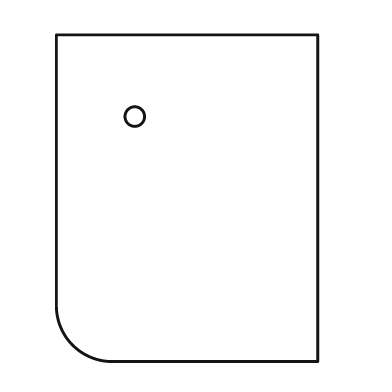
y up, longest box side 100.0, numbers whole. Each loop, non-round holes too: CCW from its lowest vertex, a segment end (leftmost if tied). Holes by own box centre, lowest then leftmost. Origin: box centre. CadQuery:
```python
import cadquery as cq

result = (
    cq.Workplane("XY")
    .moveTo(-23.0, -50.0)
    .lineTo(40.0, -50.0)
    .lineTo(40.0, 50.0)
    .lineTo(-40.0, 50.0)
    .lineTo(-40.0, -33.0)
    .threePointArc((-35.0, -45.0), (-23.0, -50.0))
    .close()
    .moveTo(-16.0, 25.0)
    .circle(3.0)
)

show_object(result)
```